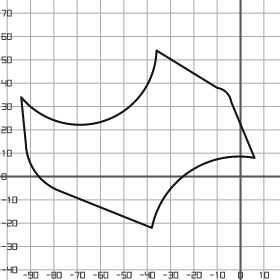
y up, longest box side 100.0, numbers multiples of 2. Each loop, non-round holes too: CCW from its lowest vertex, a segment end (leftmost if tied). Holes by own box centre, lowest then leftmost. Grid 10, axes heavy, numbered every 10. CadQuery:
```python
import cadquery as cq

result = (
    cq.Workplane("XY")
    .moveTo(-38.0, -22.0)
    .threePointArc((-22.0, 2.0), (6.0, 8.0))
    .lineTo(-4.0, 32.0)
    .threePointArc((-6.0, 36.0), (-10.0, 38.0))
    .lineTo(-36.0, 54.0)
    .threePointArc((-58.0, 24.0), (-94.0, 34.0))
    .lineTo(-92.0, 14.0)
    .threePointArc((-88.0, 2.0), (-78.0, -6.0))
    .close()
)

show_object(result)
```